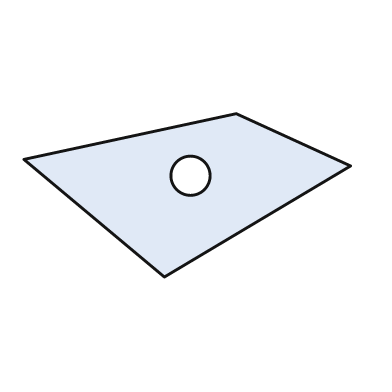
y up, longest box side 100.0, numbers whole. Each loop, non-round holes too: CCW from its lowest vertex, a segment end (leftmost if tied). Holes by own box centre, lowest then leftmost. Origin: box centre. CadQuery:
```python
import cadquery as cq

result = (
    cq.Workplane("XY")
    .moveTo(-7.0, -25.0)
    .lineTo(50.0, 9.0)
    .lineTo(15.0, 25.0)
    .lineTo(-50.0, 11.0)
    .close()
    .moveTo(1.0, 6.0)
    .circle(6.0)
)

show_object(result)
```